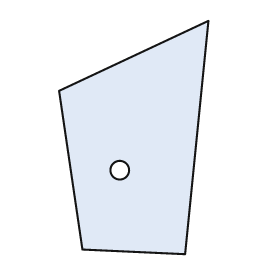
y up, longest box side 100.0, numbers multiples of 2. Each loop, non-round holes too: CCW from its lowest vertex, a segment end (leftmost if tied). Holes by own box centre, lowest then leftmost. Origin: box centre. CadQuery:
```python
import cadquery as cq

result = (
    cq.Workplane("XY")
    .moveTo(22.0, -50.0)
    .lineTo(32.0, 50.0)
    .lineTo(-32.0, 20.0)
    .lineTo(-22.0, -48.0)
    .close()
    .moveTo(-6.0, -14.0)
    .circle(4.0)
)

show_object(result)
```